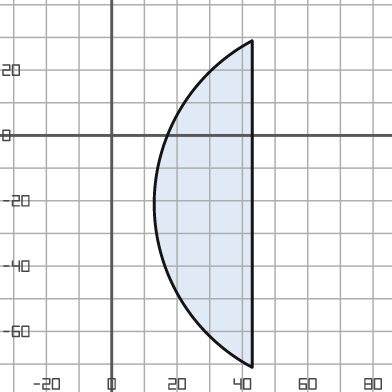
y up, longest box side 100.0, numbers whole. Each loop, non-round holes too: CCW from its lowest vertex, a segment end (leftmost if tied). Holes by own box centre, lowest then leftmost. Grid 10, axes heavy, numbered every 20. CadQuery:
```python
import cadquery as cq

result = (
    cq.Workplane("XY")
    .moveTo(43.0, -71.0)
    .lineTo(43.0, 29.0)
    .threePointArc((13.0, -21.0), (43.0, -71.0))
    .close()
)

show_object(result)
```